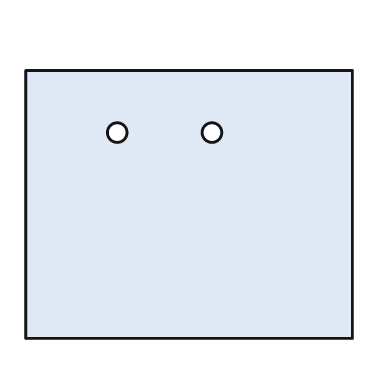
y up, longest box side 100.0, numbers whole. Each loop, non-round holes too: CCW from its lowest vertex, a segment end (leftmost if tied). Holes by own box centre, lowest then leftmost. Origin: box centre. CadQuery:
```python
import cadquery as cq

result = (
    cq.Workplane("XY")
    .moveTo(-50.0, -41.0)
    .lineTo(50.0, -41.0)
    .lineTo(50.0, 41.0)
    .lineTo(-50.0, 41.0)
    .close()
    .moveTo(-22.0, 22.0)
    .circle(3.0)
    .moveTo(7.0, 22.0)
    .circle(3.0)
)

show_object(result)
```